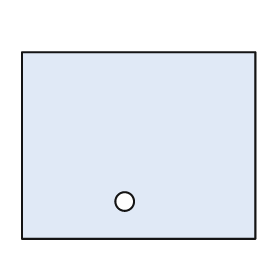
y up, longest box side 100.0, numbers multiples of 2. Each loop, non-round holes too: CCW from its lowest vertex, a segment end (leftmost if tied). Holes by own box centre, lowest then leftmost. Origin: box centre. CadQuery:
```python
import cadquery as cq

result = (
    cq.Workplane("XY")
    .moveTo(-50.0, -40.0)
    .lineTo(50.0, -40.0)
    .lineTo(50.0, 40.0)
    .lineTo(-50.0, 40.0)
    .close()
    .moveTo(-6.0, -24.0)
    .circle(4.0)
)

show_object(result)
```